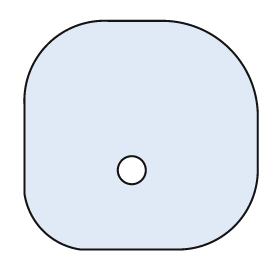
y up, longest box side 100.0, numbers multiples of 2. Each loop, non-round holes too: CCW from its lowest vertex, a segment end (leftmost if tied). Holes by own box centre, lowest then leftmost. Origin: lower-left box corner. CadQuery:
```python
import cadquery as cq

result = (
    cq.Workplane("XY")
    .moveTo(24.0, 0.0)
    .lineTo(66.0, 0.0)
    .threePointArc((90.0, 10.0), (100.0, 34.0))
    .lineTo(100.0, 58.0)
    .threePointArc((88.0, 86.0), (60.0, 98.0))
    .lineTo(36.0, 98.0)
    .threePointArc((10.0, 88.0), (0.0, 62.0))
    .lineTo(0.0, 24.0)
    .threePointArc((8.0, 8.0), (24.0, 0.0))
    .close()
    .moveTo(46.0, 34.0)
    .circle(6.0)
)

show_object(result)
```